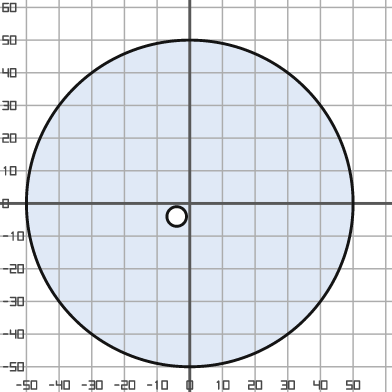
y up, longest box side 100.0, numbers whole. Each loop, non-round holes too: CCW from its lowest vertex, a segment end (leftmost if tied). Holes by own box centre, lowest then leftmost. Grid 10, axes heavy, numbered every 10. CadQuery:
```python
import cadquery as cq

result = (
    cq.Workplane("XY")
    .moveTo(0.0, 0.0)
    .circle(50.0)
    .moveTo(-4.0, -4.0)
    .circle(3.0)
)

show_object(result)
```